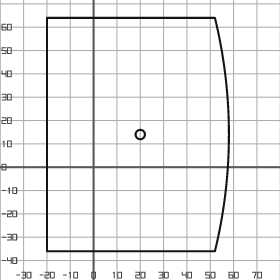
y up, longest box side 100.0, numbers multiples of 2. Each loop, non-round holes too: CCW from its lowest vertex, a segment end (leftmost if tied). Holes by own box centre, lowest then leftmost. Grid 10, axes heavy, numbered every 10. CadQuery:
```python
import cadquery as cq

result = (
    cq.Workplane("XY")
    .moveTo(-20.0, -36.0)
    .lineTo(52.0, -36.0)
    .threePointArc((58.0, 14.0), (52.0, 64.0))
    .lineTo(-20.0, 64.0)
    .close()
    .moveTo(20.0, 14.0)
    .circle(2.0)
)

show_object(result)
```